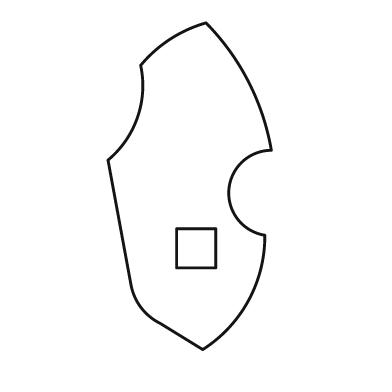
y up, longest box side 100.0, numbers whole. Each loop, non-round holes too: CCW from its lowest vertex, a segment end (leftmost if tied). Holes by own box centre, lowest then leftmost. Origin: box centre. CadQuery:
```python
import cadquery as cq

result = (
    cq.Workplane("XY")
    .moveTo(4.0, -50.0)
    .threePointArc((18.0, -35.0), (23.0, -15.0))
    .threePointArc((12.0, -1.0), (25.0, 11.0))
    .threePointArc((18.0, 32.0), (5.0, 50.0))
    .threePointArc((-6.0, 45.0), (-15.0, 37.0))
    .threePointArc((-16.0, 21.0), (-25.0, 8.0))
    .lineTo(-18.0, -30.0)
    .threePointArc((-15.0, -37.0), (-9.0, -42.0))
    .close()
    .moveTo(-4.0, -25.0)
    .lineTo(8.0, -25.0)
    .lineTo(8.0, -13.0)
    .lineTo(-4.0, -13.0)
    .close()
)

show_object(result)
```